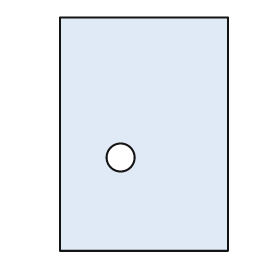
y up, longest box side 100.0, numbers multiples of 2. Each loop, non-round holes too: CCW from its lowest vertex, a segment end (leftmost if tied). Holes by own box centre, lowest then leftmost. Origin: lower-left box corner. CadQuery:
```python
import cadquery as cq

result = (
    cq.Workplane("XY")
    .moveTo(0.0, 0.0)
    .lineTo(72.0, 0.0)
    .lineTo(72.0, 100.0)
    .lineTo(0.0, 100.0)
    .close()
    .moveTo(26.0, 40.0)
    .circle(6.0)
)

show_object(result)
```